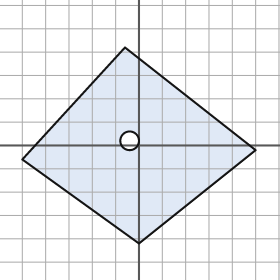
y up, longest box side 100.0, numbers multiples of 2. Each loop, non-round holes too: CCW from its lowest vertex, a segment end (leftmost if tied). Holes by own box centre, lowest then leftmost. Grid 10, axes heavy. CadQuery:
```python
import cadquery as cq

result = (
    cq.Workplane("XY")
    .moveTo(0.0, -42.0)
    .lineTo(50.0, -2.0)
    .lineTo(-6.0, 42.0)
    .lineTo(-50.0, -6.0)
    .close()
    .moveTo(-4.0, 2.0)
    .circle(4.0)
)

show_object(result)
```